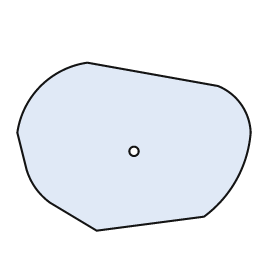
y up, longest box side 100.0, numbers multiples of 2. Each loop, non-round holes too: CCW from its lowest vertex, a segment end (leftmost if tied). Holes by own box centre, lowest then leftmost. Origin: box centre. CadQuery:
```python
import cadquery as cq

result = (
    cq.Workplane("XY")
    .moveTo(-16.0, -36.0)
    .lineTo(30.0, -30.0)
    .threePointArc((44.0, -14.0), (50.0, 6.0))
    .threePointArc((46.0, 18.0), (36.0, 26.0))
    .lineTo(-20.0, 36.0)
    .threePointArc((-40.0, 26.0), (-50.0, 6.0))
    .lineTo(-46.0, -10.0)
    .threePointArc((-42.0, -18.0), (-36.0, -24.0))
    .close()
    .moveTo(0.0, -2.0)
    .circle(2.0)
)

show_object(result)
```